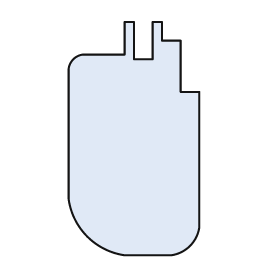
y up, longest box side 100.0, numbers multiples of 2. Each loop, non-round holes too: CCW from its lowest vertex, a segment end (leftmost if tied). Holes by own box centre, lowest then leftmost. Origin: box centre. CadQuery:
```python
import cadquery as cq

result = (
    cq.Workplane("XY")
    .moveTo(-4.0, -50.0)
    .lineTo(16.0, -50.0)
    .threePointArc((24.0, -46.0), (28.0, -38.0))
    .lineTo(28.0, 20.0)
    .lineTo(20.0, 20.0)
    .lineTo(20.0, 42.0)
    .lineTo(12.0, 42.0)
    .lineTo(12.0, 50.0)
    .lineTo(8.0, 50.0)
    .lineTo(8.0, 34.0)
    .lineTo(0.0, 34.0)
    .lineTo(0.0, 50.0)
    .lineTo(-4.0, 50.0)
    .lineTo(-4.0, 36.0)
    .lineTo(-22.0, 36.0)
    .threePointArc((-26.0, 34.0), (-28.0, 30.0))
    .lineTo(-28.0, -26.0)
    .threePointArc((-20.0, -42.0), (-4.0, -50.0))
    .close()
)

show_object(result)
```